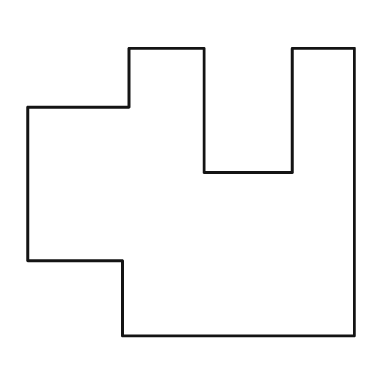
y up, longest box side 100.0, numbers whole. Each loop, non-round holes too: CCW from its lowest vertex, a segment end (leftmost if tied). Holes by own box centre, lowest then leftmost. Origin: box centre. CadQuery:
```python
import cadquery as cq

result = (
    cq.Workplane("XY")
    .moveTo(-21.0, -44.0)
    .lineTo(50.0, -44.0)
    .lineTo(50.0, 44.0)
    .lineTo(31.0, 44.0)
    .lineTo(31.0, 6.0)
    .lineTo(4.0, 6.0)
    .lineTo(4.0, 44.0)
    .lineTo(-19.0, 44.0)
    .lineTo(-19.0, 26.0)
    .lineTo(-50.0, 26.0)
    .lineTo(-50.0, -21.0)
    .lineTo(-21.0, -21.0)
    .close()
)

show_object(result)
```